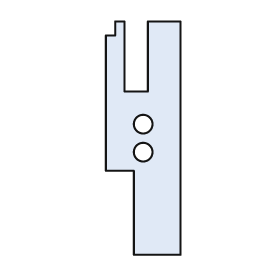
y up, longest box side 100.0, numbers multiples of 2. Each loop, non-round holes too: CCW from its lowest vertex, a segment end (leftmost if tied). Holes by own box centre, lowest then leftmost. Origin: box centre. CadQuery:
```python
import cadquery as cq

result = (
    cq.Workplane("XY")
    .moveTo(-4.0, -50.0)
    .lineTo(16.0, -50.0)
    .lineTo(16.0, 50.0)
    .lineTo(2.0, 50.0)
    .lineTo(2.0, 20.0)
    .lineTo(-8.0, 20.0)
    .lineTo(-8.0, 50.0)
    .lineTo(-12.0, 50.0)
    .lineTo(-12.0, 44.0)
    .lineTo(-16.0, 44.0)
    .lineTo(-16.0, -14.0)
    .lineTo(-4.0, -14.0)
    .close()
    .moveTo(0.0, -6.0)
    .circle(4.0)
    .moveTo(0.0, 6.0)
    .circle(4.0)
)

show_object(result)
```